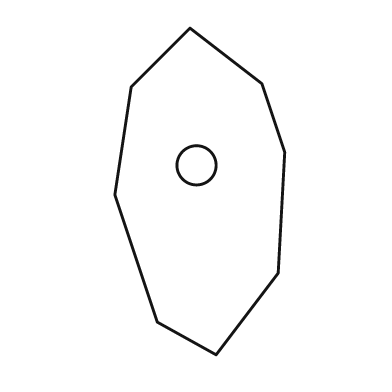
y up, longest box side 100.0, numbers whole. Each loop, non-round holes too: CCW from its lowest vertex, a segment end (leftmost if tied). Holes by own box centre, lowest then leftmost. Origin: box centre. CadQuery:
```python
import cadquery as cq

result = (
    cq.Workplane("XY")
    .moveTo(5.0, -50.0)
    .lineTo(24.0, -25.0)
    .lineTo(26.0, 12.0)
    .lineTo(19.0, 33.0)
    .lineTo(-3.0, 50.0)
    .lineTo(-21.0, 32.0)
    .lineTo(-26.0, -1.0)
    .lineTo(-13.0, -40.0)
    .close()
    .moveTo(-1.0, 8.0)
    .circle(6.0)
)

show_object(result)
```